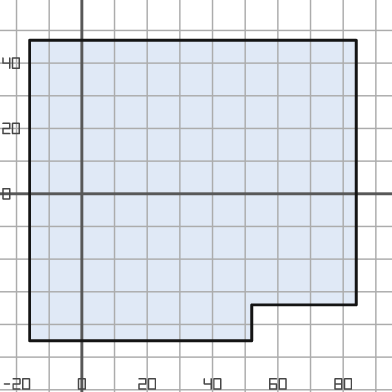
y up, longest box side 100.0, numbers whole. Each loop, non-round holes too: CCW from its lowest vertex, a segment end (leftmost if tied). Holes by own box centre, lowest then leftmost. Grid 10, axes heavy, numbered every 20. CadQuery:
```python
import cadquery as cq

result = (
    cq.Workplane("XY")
    .moveTo(-16.0, -45.0)
    .lineTo(52.0, -45.0)
    .lineTo(52.0, -34.0)
    .lineTo(84.0, -34.0)
    .lineTo(84.0, 47.0)
    .lineTo(-16.0, 47.0)
    .close()
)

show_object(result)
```